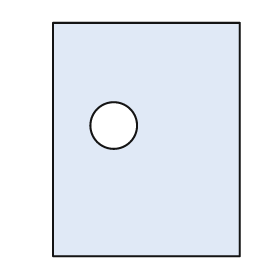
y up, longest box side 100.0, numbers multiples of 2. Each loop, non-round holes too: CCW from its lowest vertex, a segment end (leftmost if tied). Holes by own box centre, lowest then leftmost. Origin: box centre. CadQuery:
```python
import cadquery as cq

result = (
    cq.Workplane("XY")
    .moveTo(-40.0, -50.0)
    .lineTo(40.0, -50.0)
    .lineTo(40.0, 50.0)
    .lineTo(-40.0, 50.0)
    .close()
    .moveTo(-14.0, 6.0)
    .circle(10.0)
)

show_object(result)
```